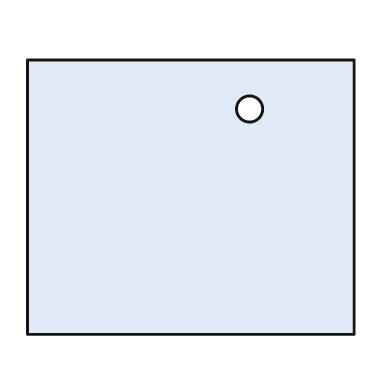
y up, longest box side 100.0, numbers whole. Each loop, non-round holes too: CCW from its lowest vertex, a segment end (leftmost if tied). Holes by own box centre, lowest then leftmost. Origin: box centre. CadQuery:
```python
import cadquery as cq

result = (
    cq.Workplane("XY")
    .moveTo(-50.0, -42.0)
    .lineTo(50.0, -42.0)
    .lineTo(50.0, 42.0)
    .lineTo(-50.0, 42.0)
    .close()
    .moveTo(18.0, 27.0)
    .circle(4.0)
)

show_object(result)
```